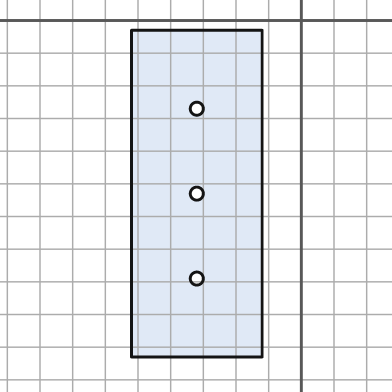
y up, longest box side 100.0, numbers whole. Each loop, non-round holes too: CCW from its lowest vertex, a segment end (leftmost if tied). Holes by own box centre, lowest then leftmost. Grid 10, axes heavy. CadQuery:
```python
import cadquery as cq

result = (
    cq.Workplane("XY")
    .moveTo(-52.0, -103.0)
    .lineTo(-12.0, -103.0)
    .lineTo(-12.0, -3.0)
    .lineTo(-52.0, -3.0)
    .close()
    .moveTo(-32.0, -79.0)
    .circle(2.0)
    .moveTo(-32.0, -53.0)
    .circle(2.0)
    .moveTo(-32.0, -27.0)
    .circle(2.0)
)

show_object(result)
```